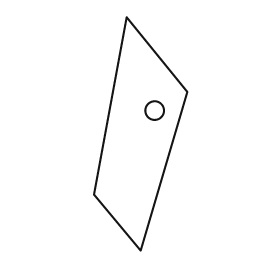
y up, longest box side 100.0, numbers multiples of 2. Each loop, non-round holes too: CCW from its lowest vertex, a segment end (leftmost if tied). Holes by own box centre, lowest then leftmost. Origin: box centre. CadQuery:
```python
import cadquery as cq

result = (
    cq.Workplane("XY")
    .moveTo(0.0, -50.0)
    .lineTo(20.0, 18.0)
    .lineTo(-6.0, 50.0)
    .lineTo(-20.0, -26.0)
    .close()
    .moveTo(6.0, 10.0)
    .circle(4.0)
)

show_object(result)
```